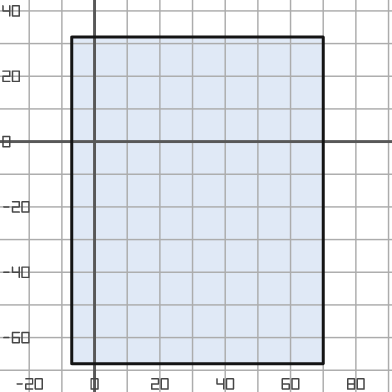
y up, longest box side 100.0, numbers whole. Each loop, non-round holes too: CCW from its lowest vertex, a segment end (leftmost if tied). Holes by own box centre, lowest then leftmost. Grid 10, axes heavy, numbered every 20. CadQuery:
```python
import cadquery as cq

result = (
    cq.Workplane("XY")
    .moveTo(-7.0, -68.0)
    .lineTo(70.0, -68.0)
    .lineTo(70.0, 32.0)
    .lineTo(-7.0, 32.0)
    .close()
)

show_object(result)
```